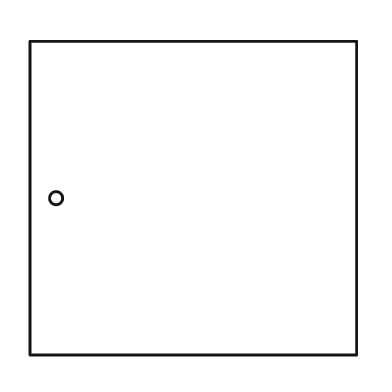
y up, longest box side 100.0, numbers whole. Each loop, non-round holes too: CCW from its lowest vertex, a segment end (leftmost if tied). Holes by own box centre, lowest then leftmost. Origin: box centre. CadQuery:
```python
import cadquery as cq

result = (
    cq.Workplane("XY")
    .moveTo(-50.0, -48.0)
    .lineTo(50.0, -48.0)
    .lineTo(50.0, 48.0)
    .lineTo(-50.0, 48.0)
    .close()
    .moveTo(-42.0, 0.0)
    .circle(2.0)
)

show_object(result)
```